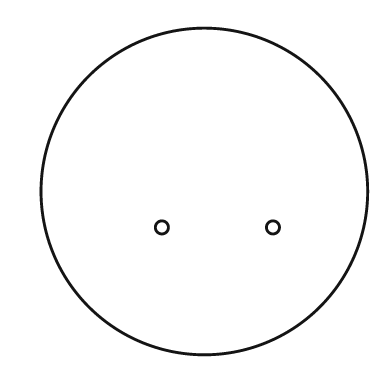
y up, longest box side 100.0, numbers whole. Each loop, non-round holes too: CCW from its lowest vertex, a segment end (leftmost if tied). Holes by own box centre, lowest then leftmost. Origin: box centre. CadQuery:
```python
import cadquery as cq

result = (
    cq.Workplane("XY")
    .moveTo(0.0, 0.0)
    .circle(50.0)
    .moveTo(-13.0, -11.0)
    .circle(2.0)
    .moveTo(21.0, -11.0)
    .circle(2.0)
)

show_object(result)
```